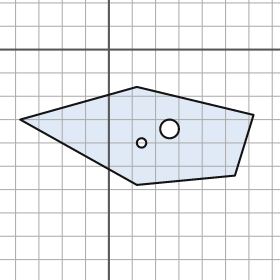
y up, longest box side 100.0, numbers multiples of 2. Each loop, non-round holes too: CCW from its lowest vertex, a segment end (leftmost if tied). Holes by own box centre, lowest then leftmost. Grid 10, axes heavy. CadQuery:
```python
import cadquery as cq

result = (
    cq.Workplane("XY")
    .moveTo(12.0, -58.0)
    .lineTo(54.0, -54.0)
    .lineTo(62.0, -28.0)
    .lineTo(12.0, -16.0)
    .lineTo(-38.0, -30.0)
    .close()
    .moveTo(14.0, -40.0)
    .circle(2.0)
    .moveTo(26.0, -34.0)
    .circle(4.0)
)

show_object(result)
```